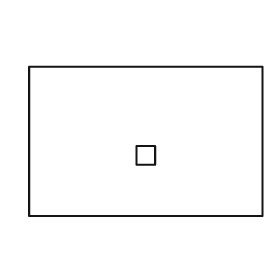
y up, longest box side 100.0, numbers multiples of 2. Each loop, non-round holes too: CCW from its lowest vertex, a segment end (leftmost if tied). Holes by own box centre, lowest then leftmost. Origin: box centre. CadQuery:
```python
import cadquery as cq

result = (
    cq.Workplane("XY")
    .moveTo(-50.0, -32.0)
    .lineTo(50.0, -32.0)
    .lineTo(50.0, 32.0)
    .lineTo(-50.0, 32.0)
    .close()
    .moveTo(-4.0, -10.0)
    .lineTo(4.0, -10.0)
    .lineTo(4.0, -2.0)
    .lineTo(-4.0, -2.0)
    .close()
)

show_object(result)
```